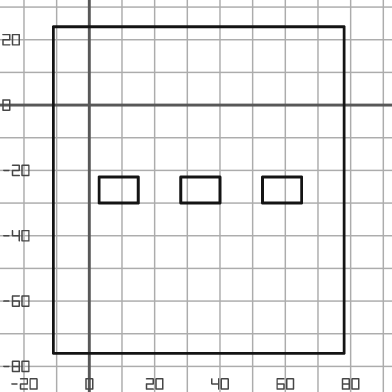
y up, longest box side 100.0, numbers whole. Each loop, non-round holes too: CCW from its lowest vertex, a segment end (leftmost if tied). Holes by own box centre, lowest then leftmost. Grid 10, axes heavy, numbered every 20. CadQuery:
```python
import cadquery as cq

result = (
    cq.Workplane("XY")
    .moveTo(-11.0, -76.0)
    .lineTo(78.0, -76.0)
    .lineTo(78.0, 24.0)
    .lineTo(-11.0, 24.0)
    .close()
    .moveTo(3.0, -30.0)
    .lineTo(15.0, -30.0)
    .lineTo(15.0, -22.0)
    .lineTo(3.0, -22.0)
    .close()
    .moveTo(28.0, -30.0)
    .lineTo(40.0, -30.0)
    .lineTo(40.0, -22.0)
    .lineTo(28.0, -22.0)
    .close()
    .moveTo(53.0, -30.0)
    .lineTo(65.0, -30.0)
    .lineTo(65.0, -22.0)
    .lineTo(53.0, -22.0)
    .close()
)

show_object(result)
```